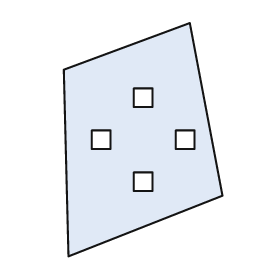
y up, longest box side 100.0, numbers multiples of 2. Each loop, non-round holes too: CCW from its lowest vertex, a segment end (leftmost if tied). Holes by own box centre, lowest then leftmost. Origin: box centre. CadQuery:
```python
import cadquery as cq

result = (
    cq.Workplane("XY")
    .moveTo(-32.0, -50.0)
    .lineTo(34.0, -24.0)
    .lineTo(20.0, 50.0)
    .lineTo(-34.0, 30.0)
    .close()
    .moveTo(-4.0, -22.0)
    .lineTo(4.0, -22.0)
    .lineTo(4.0, -14.0)
    .lineTo(-4.0, -14.0)
    .close()
    .moveTo(-22.0, -4.0)
    .lineTo(-14.0, -4.0)
    .lineTo(-14.0, 4.0)
    .lineTo(-22.0, 4.0)
    .close()
    .moveTo(14.0, -4.0)
    .lineTo(22.0, -4.0)
    .lineTo(22.0, 4.0)
    .lineTo(14.0, 4.0)
    .close()
    .moveTo(-4.0, 14.0)
    .lineTo(4.0, 14.0)
    .lineTo(4.0, 22.0)
    .lineTo(-4.0, 22.0)
    .close()
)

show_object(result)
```